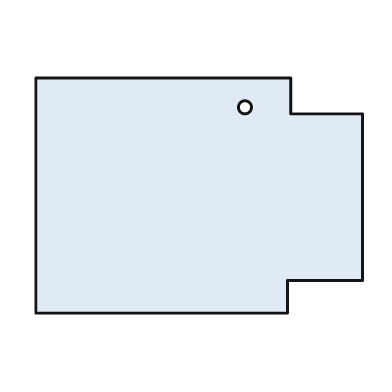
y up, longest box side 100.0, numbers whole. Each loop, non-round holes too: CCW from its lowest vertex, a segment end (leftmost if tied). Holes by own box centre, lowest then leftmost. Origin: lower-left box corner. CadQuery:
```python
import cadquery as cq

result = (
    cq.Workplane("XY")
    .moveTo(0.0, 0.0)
    .lineTo(77.0, 0.0)
    .lineTo(77.0, 10.0)
    .lineTo(100.0, 10.0)
    .lineTo(100.0, 61.0)
    .lineTo(78.0, 61.0)
    .lineTo(78.0, 72.0)
    .lineTo(0.0, 72.0)
    .close()
    .moveTo(64.0, 63.0)
    .circle(2.0)
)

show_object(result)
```